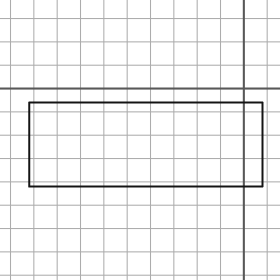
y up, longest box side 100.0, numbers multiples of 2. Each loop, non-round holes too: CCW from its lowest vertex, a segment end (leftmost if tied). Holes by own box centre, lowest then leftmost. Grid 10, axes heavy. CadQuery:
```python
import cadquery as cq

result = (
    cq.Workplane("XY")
    .moveTo(-92.0, -42.0)
    .lineTo(8.0, -42.0)
    .lineTo(8.0, -6.0)
    .lineTo(-92.0, -6.0)
    .close()
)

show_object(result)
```